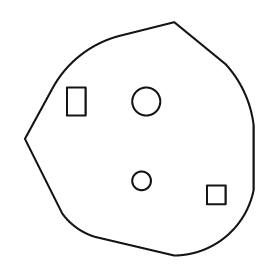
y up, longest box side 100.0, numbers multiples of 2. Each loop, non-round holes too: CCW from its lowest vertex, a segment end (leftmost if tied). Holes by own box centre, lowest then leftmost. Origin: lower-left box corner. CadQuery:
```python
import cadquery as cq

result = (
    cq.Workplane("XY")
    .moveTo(64.0, 0.0)
    .threePointArc((86.0, 8.0), (98.0, 28.0))
    .lineTo(98.0, 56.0)
    .threePointArc((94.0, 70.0), (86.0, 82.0))
    .lineTo(64.0, 100.0)
    .lineTo(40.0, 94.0)
    .threePointArc((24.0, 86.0), (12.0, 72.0))
    .lineTo(0.0, 50.0)
    .lineTo(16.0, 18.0)
    .threePointArc((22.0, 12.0), (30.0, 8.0))
    .close()
    .moveTo(78.0, 22.0)
    .lineTo(86.0, 22.0)
    .lineTo(86.0, 30.0)
    .lineTo(78.0, 30.0)
    .close()
    .moveTo(50.0, 32.0)
    .circle(4.0)
    .moveTo(18.0, 60.0)
    .lineTo(26.0, 60.0)
    .lineTo(26.0, 72.0)
    .lineTo(18.0, 72.0)
    .close()
    .moveTo(52.0, 66.0)
    .circle(6.0)
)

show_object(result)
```